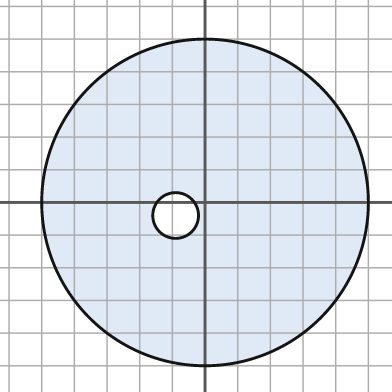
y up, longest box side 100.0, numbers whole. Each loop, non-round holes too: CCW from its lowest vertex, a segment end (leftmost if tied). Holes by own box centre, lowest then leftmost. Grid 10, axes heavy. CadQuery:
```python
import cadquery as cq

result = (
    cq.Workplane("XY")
    .moveTo(0.0, 0.0)
    .circle(50.0)
    .moveTo(-9.0, -4.0)
    .circle(7.0)
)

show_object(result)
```